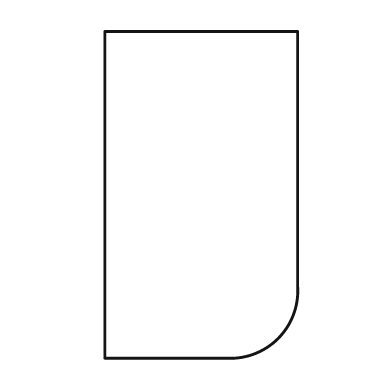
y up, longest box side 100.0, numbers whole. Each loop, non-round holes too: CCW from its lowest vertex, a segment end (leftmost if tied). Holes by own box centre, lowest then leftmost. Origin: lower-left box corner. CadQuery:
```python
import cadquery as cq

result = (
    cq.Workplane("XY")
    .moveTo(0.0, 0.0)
    .lineTo(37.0, 0.0)
    .threePointArc((53.0, 6.0), (59.0, 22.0))
    .lineTo(59.0, 100.0)
    .lineTo(0.0, 100.0)
    .close()
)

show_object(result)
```